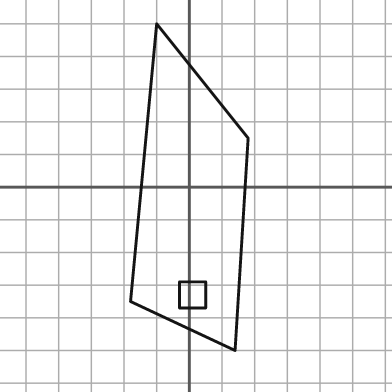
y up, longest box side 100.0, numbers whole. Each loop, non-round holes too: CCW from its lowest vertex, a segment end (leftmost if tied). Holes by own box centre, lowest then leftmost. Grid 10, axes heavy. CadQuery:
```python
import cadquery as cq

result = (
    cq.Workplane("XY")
    .moveTo(14.0, -50.0)
    .lineTo(18.0, 15.0)
    .lineTo(-10.0, 50.0)
    .lineTo(-18.0, -35.0)
    .close()
    .moveTo(-3.0, -37.0)
    .lineTo(5.0, -37.0)
    .lineTo(5.0, -29.0)
    .lineTo(-3.0, -29.0)
    .close()
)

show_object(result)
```